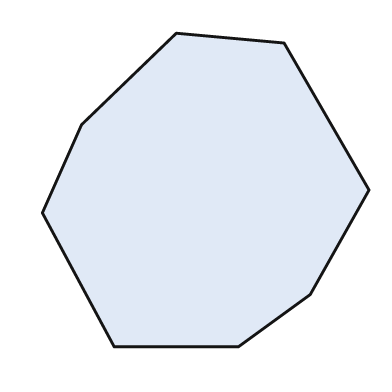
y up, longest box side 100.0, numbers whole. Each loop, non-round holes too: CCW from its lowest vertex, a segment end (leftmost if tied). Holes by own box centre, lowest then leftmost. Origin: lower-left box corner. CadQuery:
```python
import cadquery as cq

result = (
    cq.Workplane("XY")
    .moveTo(22.0, 0.0)
    .lineTo(60.0, 0.0)
    .lineTo(82.0, 16.0)
    .lineTo(100.0, 48.0)
    .lineTo(74.0, 93.0)
    .lineTo(41.0, 96.0)
    .lineTo(12.0, 68.0)
    .lineTo(0.0, 41.0)
    .close()
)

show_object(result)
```